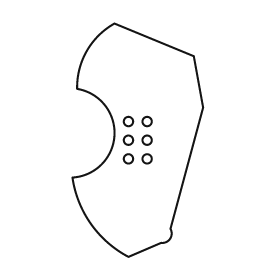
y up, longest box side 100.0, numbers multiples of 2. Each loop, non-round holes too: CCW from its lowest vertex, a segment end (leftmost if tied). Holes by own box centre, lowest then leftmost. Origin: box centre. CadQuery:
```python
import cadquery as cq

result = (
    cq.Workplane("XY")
    .moveTo(-4.0, -50.0)
    .lineTo(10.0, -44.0)
    .threePointArc((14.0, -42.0), (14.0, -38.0))
    .lineTo(28.0, 14.0)
    .lineTo(24.0, 36.0)
    .lineTo(-10.0, 50.0)
    .threePointArc((-22.0, 38.0), (-26.0, 22.0))
    .threePointArc((-10.0, 2.0), (-28.0, -16.0))
    .threePointArc((-20.0, -36.0), (-4.0, -50.0))
    .close()
    .moveTo(-4.0, -8.0)
    .circle(2.0)
    .moveTo(4.0, -8.0)
    .circle(2.0)
    .moveTo(-4.0, 0.0)
    .circle(2.0)
    .moveTo(4.0, 0.0)
    .circle(2.0)
    .moveTo(-4.0, 8.0)
    .circle(2.0)
    .moveTo(4.0, 8.0)
    .circle(2.0)
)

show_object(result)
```